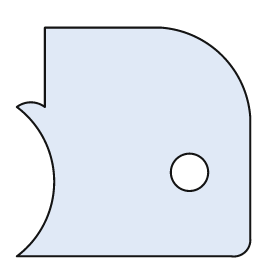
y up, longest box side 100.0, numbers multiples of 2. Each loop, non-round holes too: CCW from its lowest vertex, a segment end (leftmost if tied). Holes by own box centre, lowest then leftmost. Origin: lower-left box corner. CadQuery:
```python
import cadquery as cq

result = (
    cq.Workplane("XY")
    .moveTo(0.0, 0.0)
    .lineTo(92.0, 0.0)
    .threePointArc((98.0, 2.0), (100.0, 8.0))
    .lineTo(100.0, 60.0)
    .threePointArc((88.0, 86.0), (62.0, 98.0))
    .lineTo(12.0, 98.0)
    .lineTo(12.0, 64.0)
    .threePointArc((6.0, 66.0), (0.0, 64.0))
    .threePointArc((16.0, 32.0), (0.0, 0.0))
    .close()
    .moveTo(74.0, 36.0)
    .circle(8.0)
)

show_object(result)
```